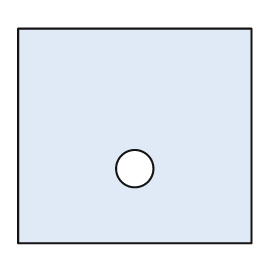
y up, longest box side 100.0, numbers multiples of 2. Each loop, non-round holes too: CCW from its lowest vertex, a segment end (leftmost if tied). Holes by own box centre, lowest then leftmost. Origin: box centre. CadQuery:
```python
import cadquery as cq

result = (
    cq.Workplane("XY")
    .moveTo(-50.0, -46.0)
    .lineTo(50.0, -46.0)
    .lineTo(50.0, 46.0)
    .lineTo(-50.0, 46.0)
    .close()
    .moveTo(0.0, -14.0)
    .circle(8.0)
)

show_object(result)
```